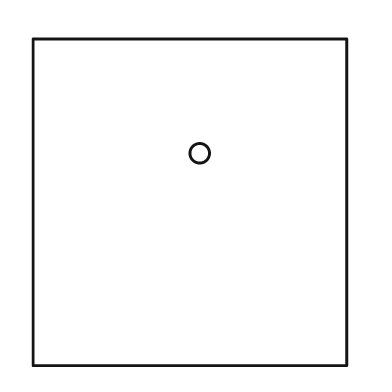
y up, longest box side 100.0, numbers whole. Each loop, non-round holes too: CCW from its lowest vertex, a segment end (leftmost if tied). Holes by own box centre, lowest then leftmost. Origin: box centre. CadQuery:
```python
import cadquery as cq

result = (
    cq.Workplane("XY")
    .moveTo(-48.0, -50.0)
    .lineTo(48.0, -50.0)
    .lineTo(48.0, 50.0)
    .lineTo(-48.0, 50.0)
    .close()
    .moveTo(3.0, 15.0)
    .circle(3.0)
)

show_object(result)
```